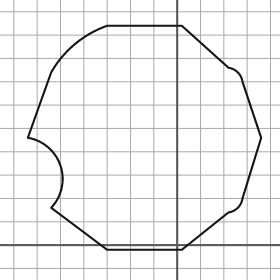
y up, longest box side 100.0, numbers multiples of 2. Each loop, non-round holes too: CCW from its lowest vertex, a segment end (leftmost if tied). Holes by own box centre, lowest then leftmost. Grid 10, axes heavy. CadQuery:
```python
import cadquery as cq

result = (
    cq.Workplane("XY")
    .moveTo(-30.0, -2.0)
    .lineTo(2.0, -2.0)
    .lineTo(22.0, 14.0)
    .threePointArc((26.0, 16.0), (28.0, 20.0))
    .lineTo(36.0, 46.0)
    .lineTo(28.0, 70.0)
    .threePointArc((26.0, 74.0), (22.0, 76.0))
    .lineTo(2.0, 94.0)
    .lineTo(-30.0, 94.0)
    .threePointArc((-44.0, 86.0), (-54.0, 74.0))
    .lineTo(-64.0, 46.0)
    .threePointArc((-50.0, 34.0), (-54.0, 16.0))
    .close()
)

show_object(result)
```